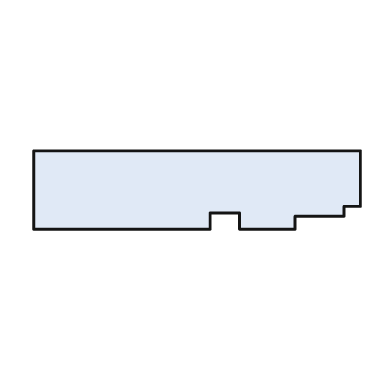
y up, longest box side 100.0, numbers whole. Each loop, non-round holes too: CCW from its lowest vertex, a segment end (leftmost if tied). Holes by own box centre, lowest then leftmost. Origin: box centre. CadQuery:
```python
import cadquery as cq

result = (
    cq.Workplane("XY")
    .moveTo(-50.0, -12.0)
    .lineTo(4.0, -12.0)
    .lineTo(4.0, -7.0)
    .lineTo(13.0, -7.0)
    .lineTo(13.0, -12.0)
    .lineTo(30.0, -12.0)
    .lineTo(30.0, -8.0)
    .lineTo(45.0, -8.0)
    .lineTo(45.0, -5.0)
    .lineTo(50.0, -5.0)
    .lineTo(50.0, 12.0)
    .lineTo(-50.0, 12.0)
    .close()
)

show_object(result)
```